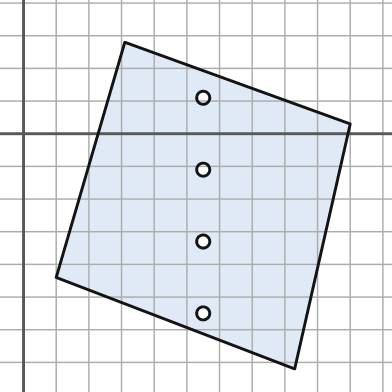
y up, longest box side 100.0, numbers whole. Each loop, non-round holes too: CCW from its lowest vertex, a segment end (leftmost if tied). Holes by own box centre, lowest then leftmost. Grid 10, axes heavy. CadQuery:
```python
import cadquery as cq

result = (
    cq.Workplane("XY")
    .moveTo(83.0, -72.0)
    .lineTo(100.0, 3.0)
    .lineTo(31.0, 28.0)
    .lineTo(10.0, -44.0)
    .close()
    .moveTo(55.0, -55.0)
    .circle(2.0)
    .moveTo(55.0, -33.0)
    .circle(2.0)
    .moveTo(55.0, -11.0)
    .circle(2.0)
    .moveTo(55.0, 11.0)
    .circle(2.0)
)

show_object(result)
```